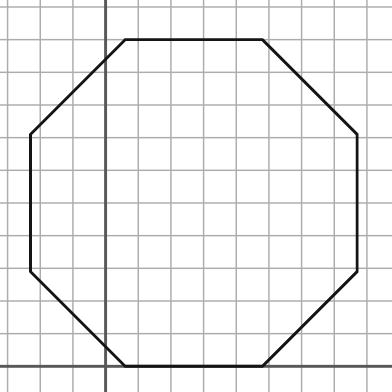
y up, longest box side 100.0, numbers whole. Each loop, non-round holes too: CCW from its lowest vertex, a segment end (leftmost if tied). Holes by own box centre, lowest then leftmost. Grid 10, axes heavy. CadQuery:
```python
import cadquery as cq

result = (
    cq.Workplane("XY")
    .moveTo(6.0, 0.0)
    .lineTo(48.0, 0.0)
    .lineTo(77.0, 29.0)
    .lineTo(77.0, 71.0)
    .lineTo(48.0, 100.0)
    .lineTo(6.0, 100.0)
    .lineTo(-23.0, 71.0)
    .lineTo(-23.0, 29.0)
    .close()
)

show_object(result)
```